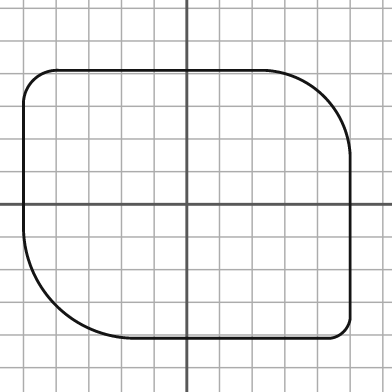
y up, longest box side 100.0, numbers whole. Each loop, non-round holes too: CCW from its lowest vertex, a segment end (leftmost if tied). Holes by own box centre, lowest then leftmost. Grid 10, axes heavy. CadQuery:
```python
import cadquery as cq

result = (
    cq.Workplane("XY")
    .moveTo(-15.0, -41.0)
    .lineTo(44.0, -41.0)
    .threePointArc((48.0, -39.0), (50.0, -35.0))
    .lineTo(50.0, 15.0)
    .threePointArc((42.0, 33.0), (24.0, 41.0))
    .lineTo(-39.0, 41.0)
    .threePointArc((-47.0, 38.0), (-50.0, 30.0))
    .lineTo(-50.0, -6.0)
    .threePointArc((-40.0, -31.0), (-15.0, -41.0))
    .close()
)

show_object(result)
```